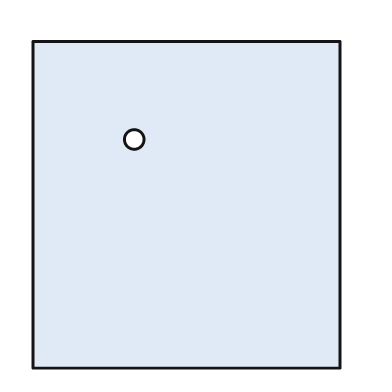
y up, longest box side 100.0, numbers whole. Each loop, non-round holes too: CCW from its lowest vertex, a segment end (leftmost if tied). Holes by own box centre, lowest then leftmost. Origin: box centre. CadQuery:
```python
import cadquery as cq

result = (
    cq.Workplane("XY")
    .moveTo(-47.0, -50.0)
    .lineTo(47.0, -50.0)
    .lineTo(47.0, 50.0)
    .lineTo(-47.0, 50.0)
    .close()
    .moveTo(-16.0, 20.0)
    .circle(3.0)
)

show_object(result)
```